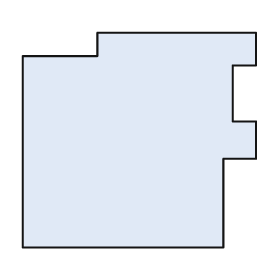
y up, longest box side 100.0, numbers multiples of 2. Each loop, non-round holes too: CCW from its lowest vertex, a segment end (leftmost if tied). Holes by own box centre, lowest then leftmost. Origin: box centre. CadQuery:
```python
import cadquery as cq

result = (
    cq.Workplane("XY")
    .moveTo(-50.0, -46.0)
    .lineTo(36.0, -46.0)
    .lineTo(36.0, -8.0)
    .lineTo(50.0, -8.0)
    .lineTo(50.0, 8.0)
    .lineTo(40.0, 8.0)
    .lineTo(40.0, 32.0)
    .lineTo(50.0, 32.0)
    .lineTo(50.0, 46.0)
    .lineTo(-18.0, 46.0)
    .lineTo(-18.0, 36.0)
    .lineTo(-50.0, 36.0)
    .close()
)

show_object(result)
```